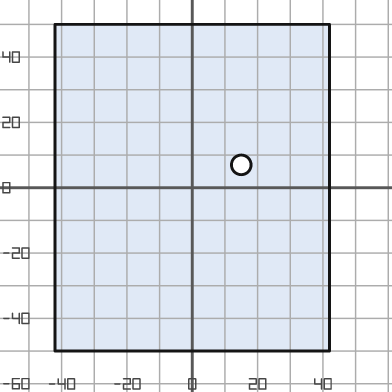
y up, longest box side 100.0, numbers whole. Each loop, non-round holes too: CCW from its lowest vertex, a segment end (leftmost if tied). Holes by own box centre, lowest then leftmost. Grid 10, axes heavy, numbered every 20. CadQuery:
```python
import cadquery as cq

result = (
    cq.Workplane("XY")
    .moveTo(-42.0, -50.0)
    .lineTo(42.0, -50.0)
    .lineTo(42.0, 50.0)
    .lineTo(-42.0, 50.0)
    .close()
    .moveTo(15.0, 7.0)
    .circle(3.0)
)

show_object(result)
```